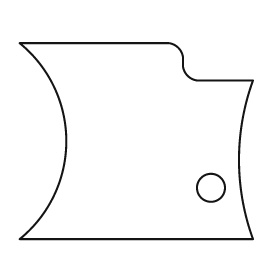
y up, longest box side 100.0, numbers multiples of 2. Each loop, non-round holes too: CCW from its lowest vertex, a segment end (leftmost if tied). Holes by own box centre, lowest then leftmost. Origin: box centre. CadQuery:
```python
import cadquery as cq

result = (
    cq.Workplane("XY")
    .moveTo(-50.0, -42.0)
    .lineTo(50.0, -42.0)
    .threePointArc((44.0, -8.0), (50.0, 26.0))
    .lineTo(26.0, 26.0)
    .threePointArc((22.0, 28.0), (20.0, 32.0))
    .lineTo(20.0, 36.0)
    .threePointArc((18.0, 40.0), (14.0, 42.0))
    .lineTo(-50.0, 42.0)
    .threePointArc((-30.0, 0.0), (-50.0, -42.0))
    .close()
    .moveTo(32.0, -20.0)
    .circle(6.0)
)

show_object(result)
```